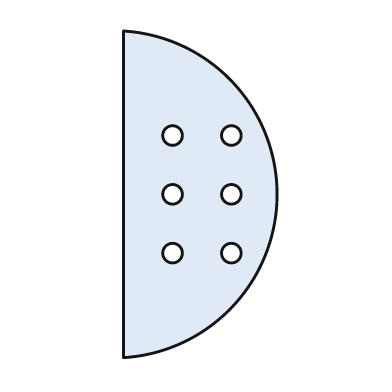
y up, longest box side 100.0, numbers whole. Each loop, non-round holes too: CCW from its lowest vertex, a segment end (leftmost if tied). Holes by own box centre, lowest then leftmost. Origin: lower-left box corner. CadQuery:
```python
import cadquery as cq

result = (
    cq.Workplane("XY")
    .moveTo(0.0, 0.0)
    .threePointArc((47.0, 50.0), (0.0, 100.0))
    .close()
    .moveTo(15.0, 32.0)
    .circle(3.0)
    .moveTo(33.0, 32.0)
    .circle(3.0)
    .moveTo(15.0, 50.0)
    .circle(3.0)
    .moveTo(33.0, 50.0)
    .circle(3.0)
    .moveTo(15.0, 68.0)
    .circle(3.0)
    .moveTo(33.0, 68.0)
    .circle(3.0)
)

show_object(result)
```